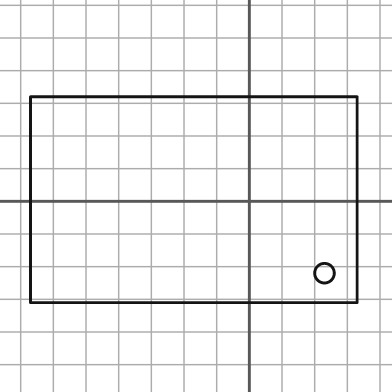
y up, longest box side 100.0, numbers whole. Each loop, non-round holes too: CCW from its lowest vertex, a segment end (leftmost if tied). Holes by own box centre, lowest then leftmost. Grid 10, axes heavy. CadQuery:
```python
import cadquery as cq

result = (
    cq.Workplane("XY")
    .moveTo(-67.0, -31.0)
    .lineTo(33.0, -31.0)
    .lineTo(33.0, 32.0)
    .lineTo(-67.0, 32.0)
    .close()
    .moveTo(23.0, -22.0)
    .circle(3.0)
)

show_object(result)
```